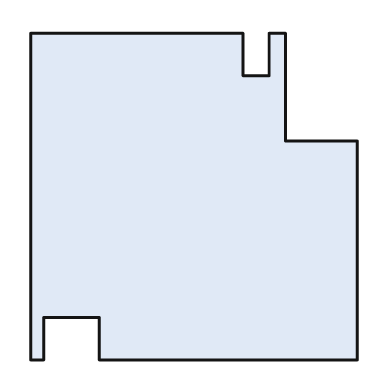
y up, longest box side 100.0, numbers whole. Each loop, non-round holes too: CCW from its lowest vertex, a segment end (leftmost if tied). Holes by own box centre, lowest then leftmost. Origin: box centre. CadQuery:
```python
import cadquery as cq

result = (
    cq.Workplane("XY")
    .moveTo(-50.0, -50.0)
    .lineTo(-46.0, -50.0)
    .lineTo(-46.0, -37.0)
    .lineTo(-29.0, -37.0)
    .lineTo(-29.0, -50.0)
    .lineTo(50.0, -50.0)
    .lineTo(50.0, 17.0)
    .lineTo(28.0, 17.0)
    .lineTo(28.0, 50.0)
    .lineTo(23.0, 50.0)
    .lineTo(23.0, 37.0)
    .lineTo(15.0, 37.0)
    .lineTo(15.0, 50.0)
    .lineTo(-50.0, 50.0)
    .close()
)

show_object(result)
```